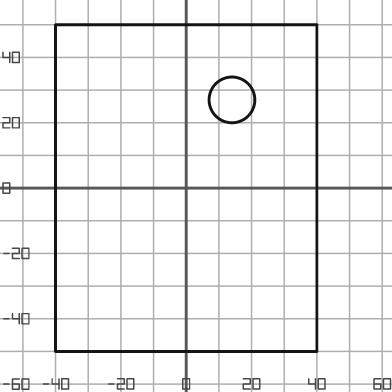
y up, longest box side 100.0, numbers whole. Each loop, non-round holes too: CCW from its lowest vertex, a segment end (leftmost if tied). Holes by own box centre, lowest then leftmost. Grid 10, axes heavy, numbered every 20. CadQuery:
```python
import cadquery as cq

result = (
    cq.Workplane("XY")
    .moveTo(-40.0, -50.0)
    .lineTo(40.0, -50.0)
    .lineTo(40.0, 50.0)
    .lineTo(-40.0, 50.0)
    .close()
    .moveTo(14.0, 27.0)
    .circle(7.0)
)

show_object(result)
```